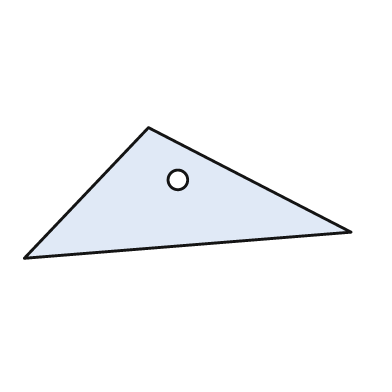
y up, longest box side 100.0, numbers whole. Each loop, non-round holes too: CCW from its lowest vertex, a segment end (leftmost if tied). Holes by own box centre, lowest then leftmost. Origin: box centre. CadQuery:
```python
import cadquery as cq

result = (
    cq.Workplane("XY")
    .moveTo(-50.0, -20.0)
    .lineTo(50.0, -12.0)
    .lineTo(-12.0, 20.0)
    .close()
    .moveTo(-3.0, 4.0)
    .circle(3.0)
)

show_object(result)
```